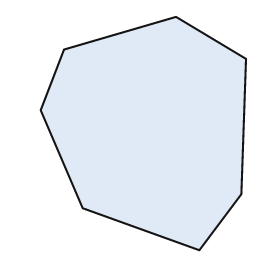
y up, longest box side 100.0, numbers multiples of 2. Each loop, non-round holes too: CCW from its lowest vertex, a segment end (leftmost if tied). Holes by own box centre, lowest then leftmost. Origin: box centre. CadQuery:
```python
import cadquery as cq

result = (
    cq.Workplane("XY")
    .moveTo(24.0, -50.0)
    .lineTo(42.0, -26.0)
    .lineTo(44.0, 32.0)
    .lineTo(14.0, 50.0)
    .lineTo(-34.0, 36.0)
    .lineTo(-44.0, 10.0)
    .lineTo(-26.0, -32.0)
    .close()
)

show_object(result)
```